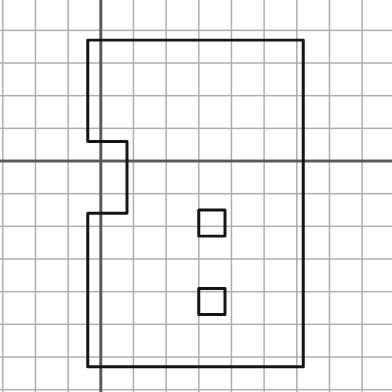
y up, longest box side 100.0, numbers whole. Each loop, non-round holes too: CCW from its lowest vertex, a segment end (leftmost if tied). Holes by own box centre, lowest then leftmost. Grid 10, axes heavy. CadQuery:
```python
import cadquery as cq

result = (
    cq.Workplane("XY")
    .moveTo(-4.0, -63.0)
    .lineTo(62.0, -63.0)
    .lineTo(62.0, 37.0)
    .lineTo(-4.0, 37.0)
    .lineTo(-4.0, 6.0)
    .lineTo(8.0, 6.0)
    .lineTo(8.0, -16.0)
    .lineTo(-4.0, -16.0)
    .close()
    .moveTo(30.0, -47.0)
    .lineTo(38.0, -47.0)
    .lineTo(38.0, -39.0)
    .lineTo(30.0, -39.0)
    .close()
    .moveTo(30.0, -23.0)
    .lineTo(38.0, -23.0)
    .lineTo(38.0, -15.0)
    .lineTo(30.0, -15.0)
    .close()
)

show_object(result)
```